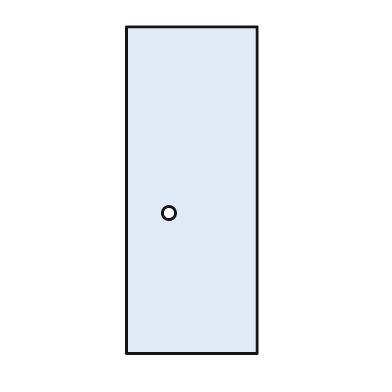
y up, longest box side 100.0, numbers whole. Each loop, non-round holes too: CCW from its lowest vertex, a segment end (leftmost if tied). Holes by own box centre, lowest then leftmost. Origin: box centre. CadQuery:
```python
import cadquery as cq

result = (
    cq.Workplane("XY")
    .moveTo(-20.0, -50.0)
    .lineTo(20.0, -50.0)
    .lineTo(20.0, 50.0)
    .lineTo(-20.0, 50.0)
    .close()
    .moveTo(-7.0, -7.0)
    .circle(2.0)
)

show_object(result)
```